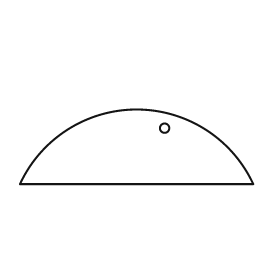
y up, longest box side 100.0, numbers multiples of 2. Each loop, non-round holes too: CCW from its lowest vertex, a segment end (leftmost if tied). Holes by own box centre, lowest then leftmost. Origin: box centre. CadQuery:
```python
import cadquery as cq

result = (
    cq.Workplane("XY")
    .moveTo(-50.0, -16.0)
    .lineTo(50.0, -16.0)
    .threePointArc((0.0, 16.0), (-50.0, -16.0))
    .close()
    .moveTo(12.0, 8.0)
    .circle(2.0)
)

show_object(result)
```